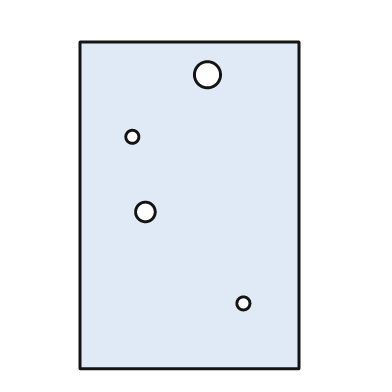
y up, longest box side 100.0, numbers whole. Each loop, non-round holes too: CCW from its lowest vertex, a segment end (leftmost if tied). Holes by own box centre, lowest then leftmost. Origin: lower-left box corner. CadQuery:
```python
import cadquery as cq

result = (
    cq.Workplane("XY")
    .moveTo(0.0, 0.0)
    .lineTo(67.0, 0.0)
    .lineTo(67.0, 100.0)
    .lineTo(0.0, 100.0)
    .close()
    .moveTo(50.0, 20.0)
    .circle(2.0)
    .moveTo(20.0, 48.0)
    .circle(3.0)
    .moveTo(16.0, 71.0)
    .circle(2.0)
    .moveTo(39.0, 90.0)
    .circle(4.0)
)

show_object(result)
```